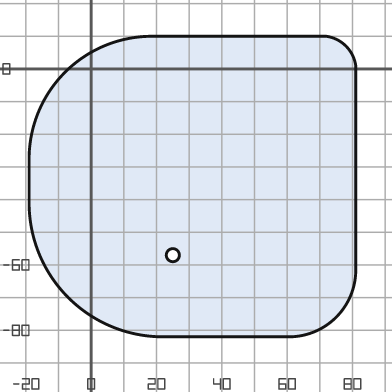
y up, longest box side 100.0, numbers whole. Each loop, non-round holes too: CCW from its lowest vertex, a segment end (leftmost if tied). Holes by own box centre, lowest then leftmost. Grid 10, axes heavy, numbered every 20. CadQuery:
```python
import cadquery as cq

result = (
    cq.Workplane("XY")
    .moveTo(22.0, -82.0)
    .lineTo(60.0, -82.0)
    .threePointArc((75.0, -76.0), (81.0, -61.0))
    .lineTo(81.0, 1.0)
    .threePointArc((78.0, 7.0), (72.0, 10.0))
    .lineTo(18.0, 10.0)
    .threePointArc((-8.0, -1.0), (-19.0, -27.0))
    .lineTo(-19.0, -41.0)
    .threePointArc((-7.0, -70.0), (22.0, -82.0))
    .close()
    .moveTo(25.0, -57.0)
    .circle(2.0)
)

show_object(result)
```